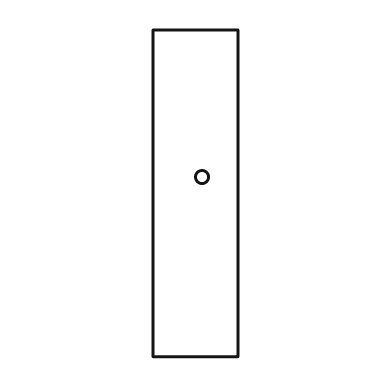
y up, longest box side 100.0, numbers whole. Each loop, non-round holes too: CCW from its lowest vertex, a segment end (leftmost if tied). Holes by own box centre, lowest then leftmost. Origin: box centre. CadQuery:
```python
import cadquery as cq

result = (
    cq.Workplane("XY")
    .moveTo(-13.0, -50.0)
    .lineTo(13.0, -50.0)
    .lineTo(13.0, 50.0)
    .lineTo(-13.0, 50.0)
    .close()
    .moveTo(2.0, 5.0)
    .circle(2.0)
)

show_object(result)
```